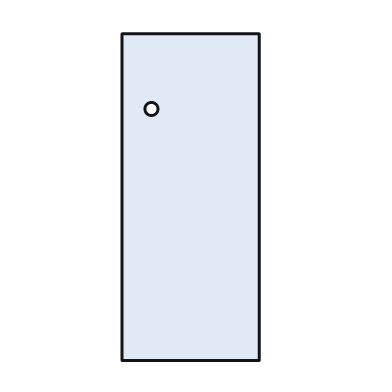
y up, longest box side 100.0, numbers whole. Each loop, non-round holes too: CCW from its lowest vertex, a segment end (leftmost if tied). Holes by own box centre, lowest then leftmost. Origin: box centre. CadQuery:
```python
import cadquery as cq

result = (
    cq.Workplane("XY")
    .moveTo(-21.0, -50.0)
    .lineTo(21.0, -50.0)
    .lineTo(21.0, 50.0)
    .lineTo(-21.0, 50.0)
    .close()
    .moveTo(-12.0, 27.0)
    .circle(2.0)
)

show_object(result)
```